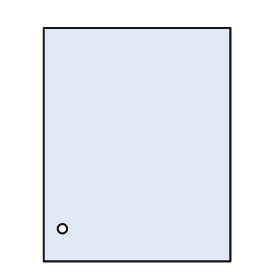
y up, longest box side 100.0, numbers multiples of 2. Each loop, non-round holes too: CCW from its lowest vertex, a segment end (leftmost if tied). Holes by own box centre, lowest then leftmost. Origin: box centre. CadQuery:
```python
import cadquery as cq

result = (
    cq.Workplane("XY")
    .moveTo(-40.0, -50.0)
    .lineTo(40.0, -50.0)
    .lineTo(40.0, 50.0)
    .lineTo(-40.0, 50.0)
    .close()
    .moveTo(-32.0, -36.0)
    .circle(2.0)
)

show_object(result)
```